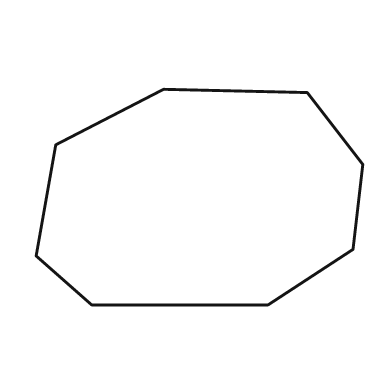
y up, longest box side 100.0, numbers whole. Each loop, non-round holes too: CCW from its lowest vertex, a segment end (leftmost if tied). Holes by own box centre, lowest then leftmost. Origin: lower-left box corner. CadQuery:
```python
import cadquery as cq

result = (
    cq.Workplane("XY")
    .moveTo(17.0, 0.0)
    .lineTo(71.0, 0.0)
    .lineTo(97.0, 17.0)
    .lineTo(100.0, 43.0)
    .lineTo(83.0, 65.0)
    .lineTo(39.0, 66.0)
    .lineTo(6.0, 49.0)
    .lineTo(0.0, 15.0)
    .close()
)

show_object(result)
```